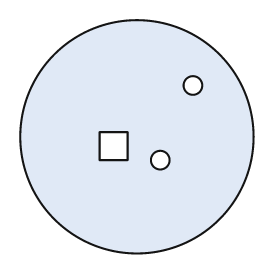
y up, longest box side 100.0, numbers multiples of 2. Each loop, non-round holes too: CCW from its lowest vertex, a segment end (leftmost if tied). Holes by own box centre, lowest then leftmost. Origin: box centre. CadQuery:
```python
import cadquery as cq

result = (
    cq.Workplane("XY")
    .moveTo(0.0, 0.0)
    .circle(50.0)
    .moveTo(10.0, -10.0)
    .circle(4.0)
    .moveTo(-16.0, -10.0)
    .lineTo(-4.0, -10.0)
    .lineTo(-4.0, 2.0)
    .lineTo(-16.0, 2.0)
    .close()
    .moveTo(24.0, 22.0)
    .circle(4.0)
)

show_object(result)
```